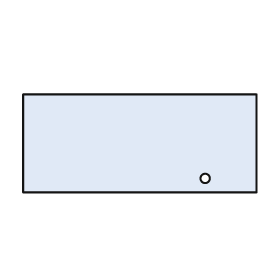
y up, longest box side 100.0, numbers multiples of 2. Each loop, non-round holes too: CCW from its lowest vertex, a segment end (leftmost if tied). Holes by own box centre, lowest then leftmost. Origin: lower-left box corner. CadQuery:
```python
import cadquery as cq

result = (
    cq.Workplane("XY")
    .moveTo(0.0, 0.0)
    .lineTo(100.0, 0.0)
    .lineTo(100.0, 42.0)
    .lineTo(0.0, 42.0)
    .close()
    .moveTo(78.0, 6.0)
    .circle(2.0)
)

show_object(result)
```